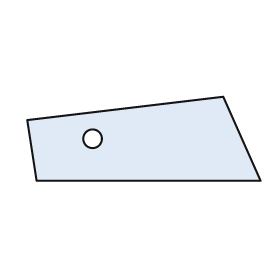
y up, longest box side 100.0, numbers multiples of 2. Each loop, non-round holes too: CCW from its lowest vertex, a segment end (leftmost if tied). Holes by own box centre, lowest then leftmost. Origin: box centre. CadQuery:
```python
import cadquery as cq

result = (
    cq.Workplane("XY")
    .moveTo(-46.0, -18.0)
    .lineTo(50.0, -18.0)
    .lineTo(34.0, 18.0)
    .lineTo(-50.0, 8.0)
    .close()
    .moveTo(-22.0, 0.0)
    .circle(4.0)
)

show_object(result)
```